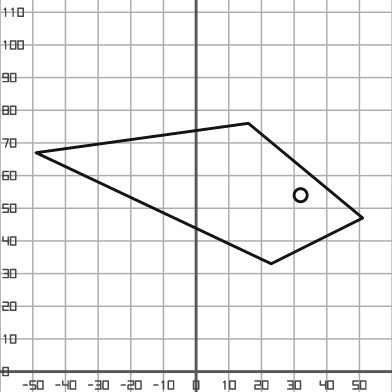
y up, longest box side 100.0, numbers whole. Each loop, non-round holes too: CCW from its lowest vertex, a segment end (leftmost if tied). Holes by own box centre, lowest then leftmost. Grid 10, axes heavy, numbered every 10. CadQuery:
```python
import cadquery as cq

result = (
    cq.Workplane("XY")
    .moveTo(23.0, 33.0)
    .lineTo(51.0, 47.0)
    .lineTo(16.0, 76.0)
    .lineTo(-49.0, 67.0)
    .close()
    .moveTo(32.0, 54.0)
    .circle(2.0)
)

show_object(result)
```